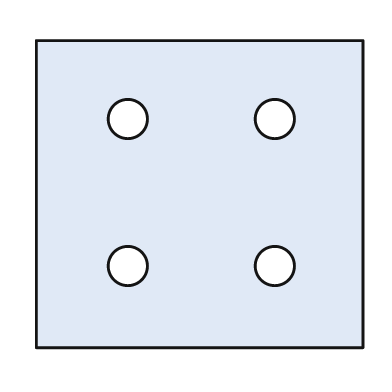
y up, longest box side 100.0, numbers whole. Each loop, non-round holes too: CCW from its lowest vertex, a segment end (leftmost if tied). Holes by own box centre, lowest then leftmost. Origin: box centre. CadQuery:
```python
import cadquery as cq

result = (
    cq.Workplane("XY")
    .moveTo(-50.0, -47.0)
    .lineTo(50.0, -47.0)
    .lineTo(50.0, 47.0)
    .lineTo(-50.0, 47.0)
    .close()
    .moveTo(-22.0, -22.0)
    .circle(6.0)
    .moveTo(23.0, -22.0)
    .circle(6.0)
    .moveTo(-22.0, 23.0)
    .circle(6.0)
    .moveTo(23.0, 23.0)
    .circle(6.0)
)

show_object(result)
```